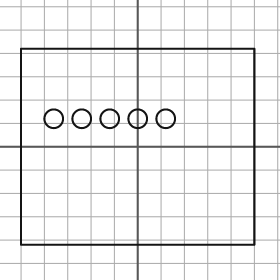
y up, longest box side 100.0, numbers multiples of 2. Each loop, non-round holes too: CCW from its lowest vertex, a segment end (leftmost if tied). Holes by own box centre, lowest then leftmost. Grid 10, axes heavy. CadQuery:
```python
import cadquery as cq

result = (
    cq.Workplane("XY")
    .moveTo(-50.0, -42.0)
    .lineTo(50.0, -42.0)
    .lineTo(50.0, 42.0)
    .lineTo(-50.0, 42.0)
    .close()
    .moveTo(-36.0, 12.0)
    .circle(4.0)
    .moveTo(-24.0, 12.0)
    .circle(4.0)
    .moveTo(-12.0, 12.0)
    .circle(4.0)
    .moveTo(0.0, 12.0)
    .circle(4.0)
    .moveTo(12.0, 12.0)
    .circle(4.0)
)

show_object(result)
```